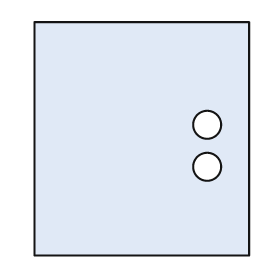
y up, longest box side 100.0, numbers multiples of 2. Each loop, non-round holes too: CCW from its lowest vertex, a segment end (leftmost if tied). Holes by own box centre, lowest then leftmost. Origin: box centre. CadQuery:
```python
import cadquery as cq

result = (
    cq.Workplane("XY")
    .moveTo(-46.0, -50.0)
    .lineTo(46.0, -50.0)
    .lineTo(46.0, 50.0)
    .lineTo(-46.0, 50.0)
    .close()
    .moveTo(28.0, -12.0)
    .circle(6.0)
    .moveTo(28.0, 6.0)
    .circle(6.0)
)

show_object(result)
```